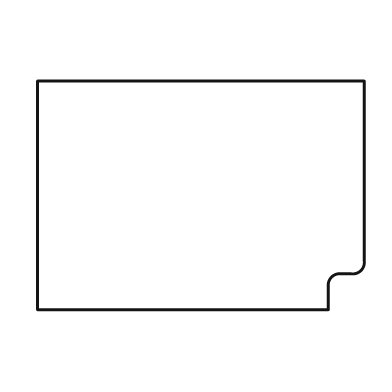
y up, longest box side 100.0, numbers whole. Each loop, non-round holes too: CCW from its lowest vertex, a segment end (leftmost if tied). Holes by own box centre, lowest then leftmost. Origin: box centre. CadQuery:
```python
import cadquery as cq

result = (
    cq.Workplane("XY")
    .moveTo(-50.0, -35.0)
    .lineTo(39.0, -35.0)
    .lineTo(39.0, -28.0)
    .threePointArc((40.0, -25.0), (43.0, -24.0))
    .lineTo(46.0, -24.0)
    .threePointArc((49.0, -23.0), (50.0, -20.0))
    .lineTo(50.0, 35.0)
    .lineTo(-50.0, 35.0)
    .close()
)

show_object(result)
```